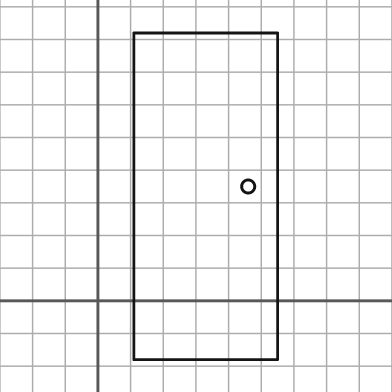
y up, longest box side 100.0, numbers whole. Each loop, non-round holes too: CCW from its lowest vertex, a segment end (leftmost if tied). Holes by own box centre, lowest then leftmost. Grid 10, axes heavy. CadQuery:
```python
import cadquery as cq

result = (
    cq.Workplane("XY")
    .moveTo(11.0, -18.0)
    .lineTo(55.0, -18.0)
    .lineTo(55.0, 82.0)
    .lineTo(11.0, 82.0)
    .close()
    .moveTo(46.0, 35.0)
    .circle(2.0)
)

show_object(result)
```